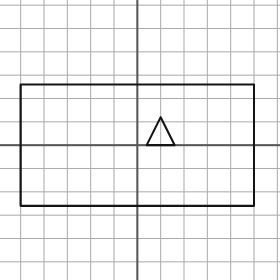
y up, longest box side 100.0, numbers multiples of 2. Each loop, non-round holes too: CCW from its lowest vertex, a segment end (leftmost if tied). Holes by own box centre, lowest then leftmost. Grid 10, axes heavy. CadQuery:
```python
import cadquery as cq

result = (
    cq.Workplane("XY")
    .moveTo(-50.0, -26.0)
    .lineTo(50.0, -26.0)
    .lineTo(50.0, 26.0)
    .lineTo(-50.0, 26.0)
    .close()
    .moveTo(4.0, 0.0)
    .lineTo(16.0, 0.0)
    .lineTo(10.0, 12.0)
    .close()
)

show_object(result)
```